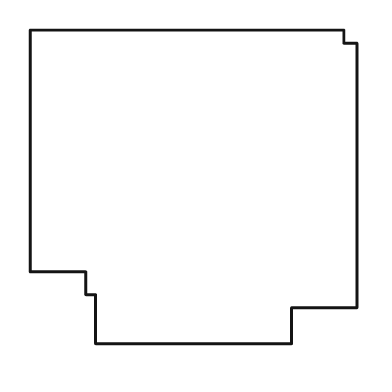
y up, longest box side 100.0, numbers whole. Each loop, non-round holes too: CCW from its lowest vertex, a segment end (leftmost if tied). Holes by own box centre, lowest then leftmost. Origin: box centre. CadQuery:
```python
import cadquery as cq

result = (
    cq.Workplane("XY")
    .moveTo(-30.0, -48.0)
    .lineTo(30.0, -48.0)
    .lineTo(30.0, -37.0)
    .lineTo(50.0, -37.0)
    .lineTo(50.0, 44.0)
    .lineTo(46.0, 44.0)
    .lineTo(46.0, 48.0)
    .lineTo(-50.0, 48.0)
    .lineTo(-50.0, -26.0)
    .lineTo(-33.0, -26.0)
    .lineTo(-33.0, -33.0)
    .lineTo(-30.0, -33.0)
    .close()
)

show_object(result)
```